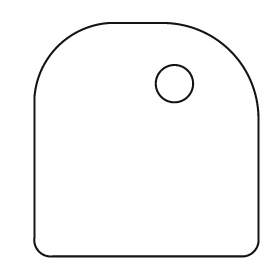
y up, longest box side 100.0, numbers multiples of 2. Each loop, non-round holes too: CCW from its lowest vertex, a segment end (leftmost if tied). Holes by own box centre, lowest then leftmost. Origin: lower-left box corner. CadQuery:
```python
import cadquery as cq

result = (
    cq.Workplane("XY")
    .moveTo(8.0, 0.0)
    .lineTo(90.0, 0.0)
    .threePointArc((94.0, 2.0), (96.0, 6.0))
    .lineTo(96.0, 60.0)
    .threePointArc((84.0, 88.0), (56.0, 100.0))
    .lineTo(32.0, 100.0)
    .threePointArc((10.0, 90.0), (0.0, 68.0))
    .lineTo(0.0, 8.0)
    .threePointArc((2.0, 2.0), (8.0, 0.0))
    .close()
    .moveTo(60.0, 74.0)
    .circle(8.0)
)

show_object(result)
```